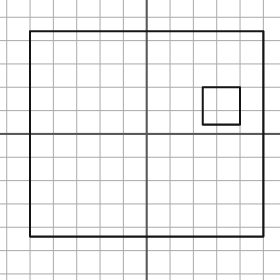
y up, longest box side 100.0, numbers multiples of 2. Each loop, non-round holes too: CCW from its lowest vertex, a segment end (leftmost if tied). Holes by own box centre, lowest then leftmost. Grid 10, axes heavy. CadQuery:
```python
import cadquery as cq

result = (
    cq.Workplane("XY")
    .moveTo(-50.0, -44.0)
    .lineTo(50.0, -44.0)
    .lineTo(50.0, 44.0)
    .lineTo(-50.0, 44.0)
    .close()
    .moveTo(24.0, 4.0)
    .lineTo(40.0, 4.0)
    .lineTo(40.0, 20.0)
    .lineTo(24.0, 20.0)
    .close()
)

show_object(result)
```